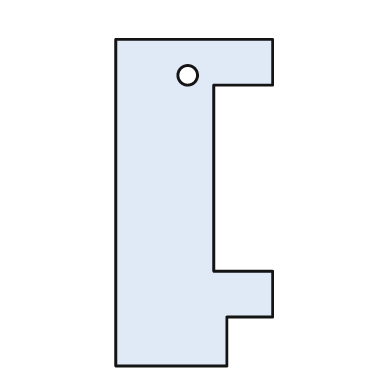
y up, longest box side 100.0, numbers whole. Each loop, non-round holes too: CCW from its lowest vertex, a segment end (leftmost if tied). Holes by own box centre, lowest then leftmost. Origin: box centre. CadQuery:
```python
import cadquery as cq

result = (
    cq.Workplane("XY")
    .moveTo(-24.0, -50.0)
    .lineTo(10.0, -50.0)
    .lineTo(10.0, -35.0)
    .lineTo(24.0, -35.0)
    .lineTo(24.0, -21.0)
    .lineTo(6.0, -21.0)
    .lineTo(6.0, 36.0)
    .lineTo(24.0, 36.0)
    .lineTo(24.0, 50.0)
    .lineTo(-24.0, 50.0)
    .close()
    .moveTo(-2.0, 39.0)
    .circle(3.0)
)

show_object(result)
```